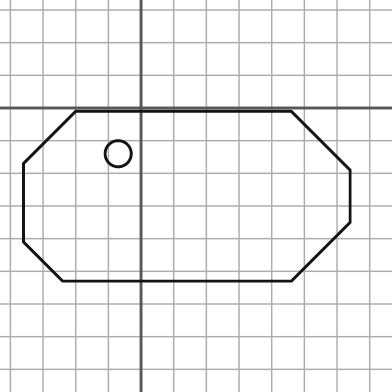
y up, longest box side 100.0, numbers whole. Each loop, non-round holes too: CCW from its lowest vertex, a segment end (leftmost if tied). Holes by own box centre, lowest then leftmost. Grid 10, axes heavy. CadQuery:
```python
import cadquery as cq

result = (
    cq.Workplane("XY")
    .moveTo(-24.0, -53.0)
    .lineTo(46.0, -53.0)
    .lineTo(64.0, -35.0)
    .lineTo(64.0, -19.0)
    .lineTo(46.0, -1.0)
    .lineTo(-20.0, -1.0)
    .lineTo(-36.0, -17.0)
    .lineTo(-36.0, -41.0)
    .close()
    .moveTo(-7.0, -14.0)
    .circle(4.0)
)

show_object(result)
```